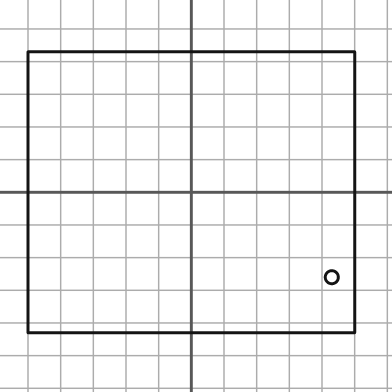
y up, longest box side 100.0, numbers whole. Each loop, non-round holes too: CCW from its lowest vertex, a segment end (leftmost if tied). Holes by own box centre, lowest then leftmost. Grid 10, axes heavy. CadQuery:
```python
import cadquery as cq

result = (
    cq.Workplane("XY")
    .moveTo(-50.0, -43.0)
    .lineTo(50.0, -43.0)
    .lineTo(50.0, 43.0)
    .lineTo(-50.0, 43.0)
    .close()
    .moveTo(43.0, -26.0)
    .circle(2.0)
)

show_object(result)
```